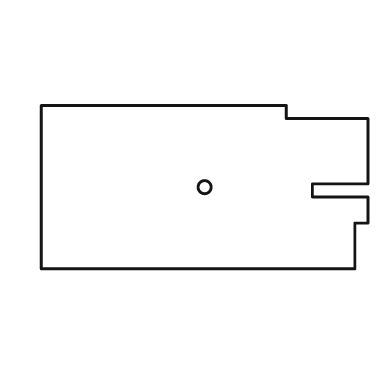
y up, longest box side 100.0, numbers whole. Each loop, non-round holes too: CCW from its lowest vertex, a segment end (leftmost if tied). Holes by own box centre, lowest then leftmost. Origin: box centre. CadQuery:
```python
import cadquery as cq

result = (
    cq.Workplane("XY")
    .moveTo(-50.0, -25.0)
    .lineTo(46.0, -25.0)
    .lineTo(46.0, -11.0)
    .lineTo(50.0, -11.0)
    .lineTo(50.0, -3.0)
    .lineTo(33.0, -3.0)
    .lineTo(33.0, 1.0)
    .lineTo(50.0, 1.0)
    .lineTo(50.0, 21.0)
    .lineTo(25.0, 21.0)
    .lineTo(25.0, 25.0)
    .lineTo(-50.0, 25.0)
    .close()
    .moveTo(0.0, 0.0)
    .circle(2.0)
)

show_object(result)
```